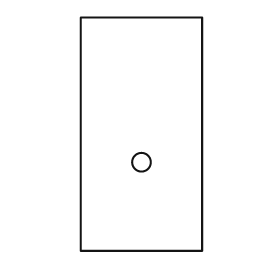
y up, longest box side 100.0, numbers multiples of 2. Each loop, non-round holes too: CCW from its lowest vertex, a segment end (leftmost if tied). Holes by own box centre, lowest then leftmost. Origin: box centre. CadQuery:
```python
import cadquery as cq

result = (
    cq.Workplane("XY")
    .moveTo(-26.0, -50.0)
    .lineTo(26.0, -50.0)
    .lineTo(26.0, 50.0)
    .lineTo(-26.0, 50.0)
    .close()
    .moveTo(0.0, -12.0)
    .circle(4.0)
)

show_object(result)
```